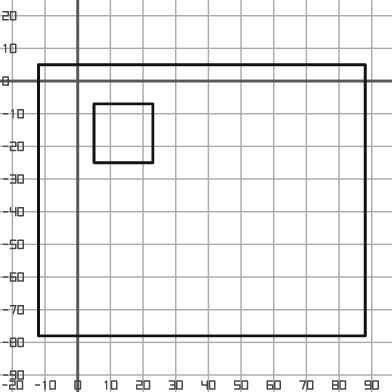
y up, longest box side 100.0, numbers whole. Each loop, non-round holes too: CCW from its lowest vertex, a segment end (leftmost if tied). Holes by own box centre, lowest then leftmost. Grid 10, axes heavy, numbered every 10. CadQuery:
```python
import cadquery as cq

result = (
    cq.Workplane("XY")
    .moveTo(-12.0, -78.0)
    .lineTo(88.0, -78.0)
    .lineTo(88.0, 5.0)
    .lineTo(-12.0, 5.0)
    .close()
    .moveTo(5.0, -25.0)
    .lineTo(23.0, -25.0)
    .lineTo(23.0, -7.0)
    .lineTo(5.0, -7.0)
    .close()
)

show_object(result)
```